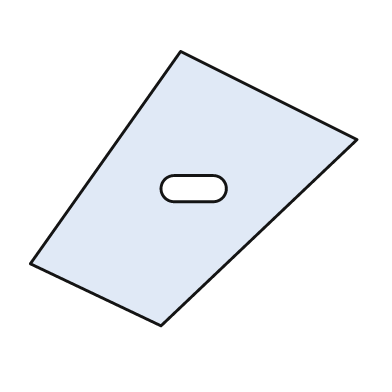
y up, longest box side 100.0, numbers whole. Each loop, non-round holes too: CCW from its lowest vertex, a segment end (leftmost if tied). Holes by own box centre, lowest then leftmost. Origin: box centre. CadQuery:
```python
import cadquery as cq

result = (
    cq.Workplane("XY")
    .moveTo(-10.0, -42.0)
    .lineTo(50.0, 15.0)
    .lineTo(-4.0, 42.0)
    .lineTo(-50.0, -23.0)
    .close()
    .moveTo(-6.0, -4.0)
    .lineTo(6.0, -4.0)
    .threePointArc((10.0, 0.0), (6.0, 4.0))
    .lineTo(-6.0, 4.0)
    .threePointArc((-10.0, 0.0), (-6.0, -4.0))
    .close()
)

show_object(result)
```